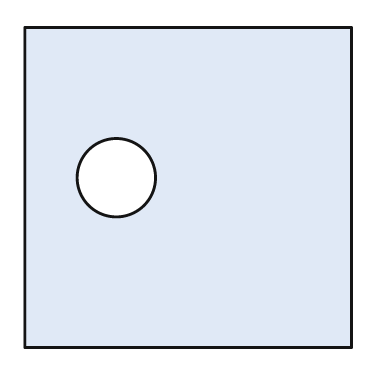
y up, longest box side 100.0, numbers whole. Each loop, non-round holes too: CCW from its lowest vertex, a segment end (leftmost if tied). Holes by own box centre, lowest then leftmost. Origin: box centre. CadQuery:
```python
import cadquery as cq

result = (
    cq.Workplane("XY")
    .moveTo(-50.0, -49.0)
    .lineTo(50.0, -49.0)
    .lineTo(50.0, 49.0)
    .lineTo(-50.0, 49.0)
    .close()
    .moveTo(-22.0, 3.0)
    .circle(12.0)
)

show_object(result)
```